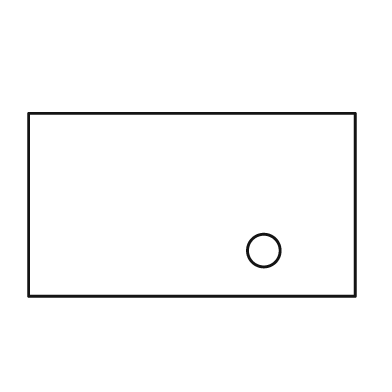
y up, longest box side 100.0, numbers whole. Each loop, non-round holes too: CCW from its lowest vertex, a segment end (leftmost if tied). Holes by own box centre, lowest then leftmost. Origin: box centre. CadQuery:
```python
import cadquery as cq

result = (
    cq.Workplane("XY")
    .moveTo(-50.0, -28.0)
    .lineTo(50.0, -28.0)
    .lineTo(50.0, 28.0)
    .lineTo(-50.0, 28.0)
    .close()
    .moveTo(22.0, -14.0)
    .circle(5.0)
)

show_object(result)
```